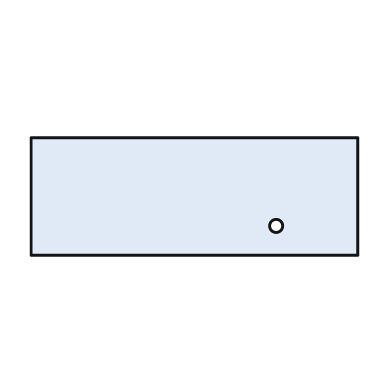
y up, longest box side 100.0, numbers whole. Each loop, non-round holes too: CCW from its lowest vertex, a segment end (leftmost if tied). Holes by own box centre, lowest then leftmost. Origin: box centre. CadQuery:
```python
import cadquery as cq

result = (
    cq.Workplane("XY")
    .moveTo(-50.0, -18.0)
    .lineTo(50.0, -18.0)
    .lineTo(50.0, 18.0)
    .lineTo(-50.0, 18.0)
    .close()
    .moveTo(25.0, -9.0)
    .circle(2.0)
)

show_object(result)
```